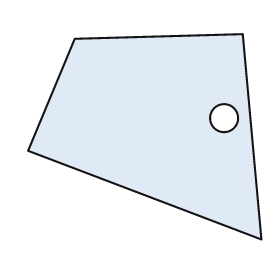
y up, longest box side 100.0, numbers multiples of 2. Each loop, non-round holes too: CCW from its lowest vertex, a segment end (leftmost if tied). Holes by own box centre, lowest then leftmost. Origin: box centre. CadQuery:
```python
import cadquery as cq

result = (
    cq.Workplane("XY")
    .moveTo(50.0, -44.0)
    .lineTo(42.0, 44.0)
    .lineTo(-30.0, 42.0)
    .lineTo(-50.0, -6.0)
    .close()
    .moveTo(34.0, 8.0)
    .circle(6.0)
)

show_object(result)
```